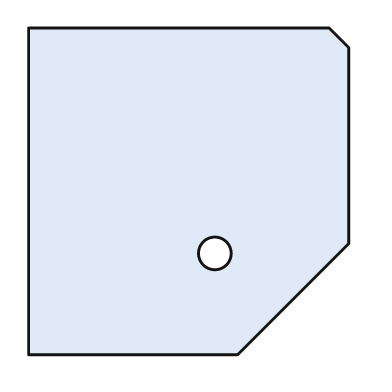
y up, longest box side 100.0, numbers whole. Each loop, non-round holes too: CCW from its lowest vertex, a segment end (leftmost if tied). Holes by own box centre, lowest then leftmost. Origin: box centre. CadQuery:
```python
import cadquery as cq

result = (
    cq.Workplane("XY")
    .moveTo(-49.0, -50.0)
    .lineTo(15.0, -50.0)
    .lineTo(49.0, -16.0)
    .lineTo(49.0, 44.0)
    .lineTo(43.0, 50.0)
    .lineTo(-49.0, 50.0)
    .close()
    .moveTo(8.0, -19.0)
    .circle(5.0)
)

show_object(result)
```